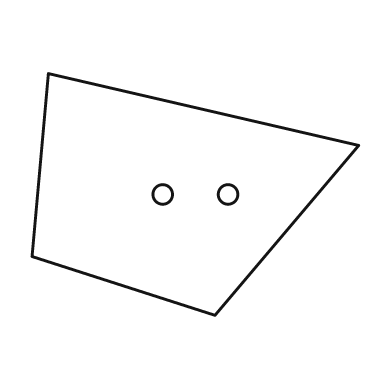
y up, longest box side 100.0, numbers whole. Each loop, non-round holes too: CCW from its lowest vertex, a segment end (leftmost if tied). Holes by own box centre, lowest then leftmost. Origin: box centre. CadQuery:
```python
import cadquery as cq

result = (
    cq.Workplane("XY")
    .moveTo(6.0, -37.0)
    .lineTo(50.0, 15.0)
    .lineTo(-45.0, 37.0)
    .lineTo(-50.0, -19.0)
    .close()
    .moveTo(-10.0, 0.0)
    .circle(3.0)
    .moveTo(10.0, 0.0)
    .circle(3.0)
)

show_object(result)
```